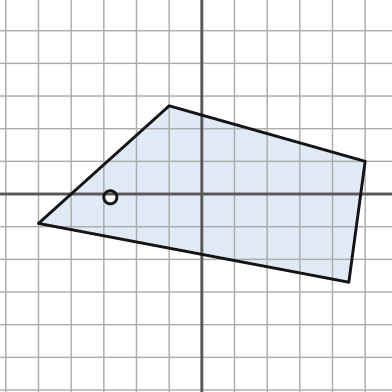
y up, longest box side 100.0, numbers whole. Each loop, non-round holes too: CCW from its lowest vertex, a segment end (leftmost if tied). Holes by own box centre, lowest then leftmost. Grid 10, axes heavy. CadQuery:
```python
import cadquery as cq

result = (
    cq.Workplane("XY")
    .moveTo(45.0, -27.0)
    .lineTo(50.0, 10.0)
    .lineTo(-10.0, 27.0)
    .lineTo(-50.0, -9.0)
    .close()
    .moveTo(-28.0, -1.0)
    .circle(2.0)
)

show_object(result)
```